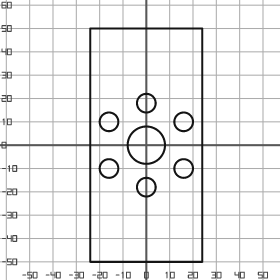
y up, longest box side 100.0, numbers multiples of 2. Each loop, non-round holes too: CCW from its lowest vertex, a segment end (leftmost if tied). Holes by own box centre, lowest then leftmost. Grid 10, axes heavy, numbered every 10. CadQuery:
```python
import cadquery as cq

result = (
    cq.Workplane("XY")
    .moveTo(-24.0, -50.0)
    .lineTo(24.0, -50.0)
    .lineTo(24.0, 50.0)
    .lineTo(-24.0, 50.0)
    .close()
    .moveTo(0.0, -18.0)
    .circle(4.0)
    .moveTo(-16.0, -10.0)
    .circle(4.0)
    .moveTo(16.0, -10.0)
    .circle(4.0)
    .moveTo(0.0, 0.0)
    .circle(8.0)
    .moveTo(-16.0, 10.0)
    .circle(4.0)
    .moveTo(16.0, 10.0)
    .circle(4.0)
    .moveTo(0.0, 18.0)
    .circle(4.0)
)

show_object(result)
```